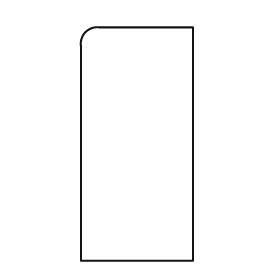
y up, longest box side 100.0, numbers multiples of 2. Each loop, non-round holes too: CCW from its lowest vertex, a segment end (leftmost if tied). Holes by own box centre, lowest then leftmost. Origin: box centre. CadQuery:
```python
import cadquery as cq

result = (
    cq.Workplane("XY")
    .moveTo(-24.0, -50.0)
    .lineTo(24.0, -50.0)
    .lineTo(24.0, 50.0)
    .lineTo(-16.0, 50.0)
    .threePointArc((-22.0, 48.0), (-24.0, 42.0))
    .close()
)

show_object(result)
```